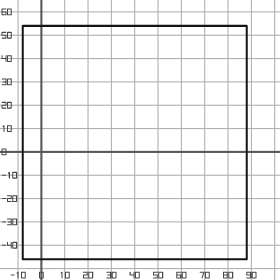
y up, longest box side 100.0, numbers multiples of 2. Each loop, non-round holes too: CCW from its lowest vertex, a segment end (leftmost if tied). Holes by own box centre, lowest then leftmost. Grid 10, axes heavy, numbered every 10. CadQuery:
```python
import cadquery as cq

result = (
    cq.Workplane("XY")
    .moveTo(-8.0, -46.0)
    .lineTo(88.0, -46.0)
    .lineTo(88.0, 54.0)
    .lineTo(-8.0, 54.0)
    .close()
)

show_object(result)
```